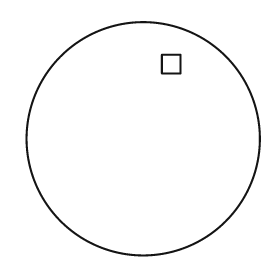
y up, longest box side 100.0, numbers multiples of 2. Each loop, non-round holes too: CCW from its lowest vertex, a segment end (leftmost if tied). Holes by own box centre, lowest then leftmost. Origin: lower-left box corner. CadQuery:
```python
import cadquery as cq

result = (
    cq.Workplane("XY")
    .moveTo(50.0, 50.0)
    .circle(50.0)
    .moveTo(58.0, 78.0)
    .lineTo(66.0, 78.0)
    .lineTo(66.0, 86.0)
    .lineTo(58.0, 86.0)
    .close()
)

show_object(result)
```